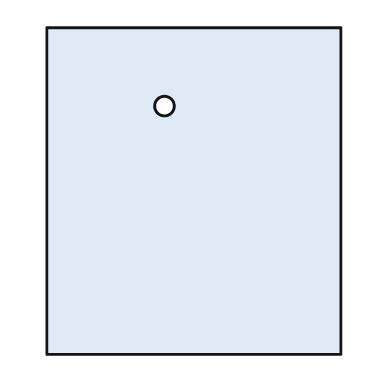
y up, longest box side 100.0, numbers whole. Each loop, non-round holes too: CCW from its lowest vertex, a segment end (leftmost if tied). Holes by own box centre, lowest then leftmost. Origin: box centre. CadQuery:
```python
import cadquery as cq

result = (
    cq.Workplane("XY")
    .moveTo(-45.0, -50.0)
    .lineTo(45.0, -50.0)
    .lineTo(45.0, 50.0)
    .lineTo(-45.0, 50.0)
    .close()
    .moveTo(-9.0, 26.0)
    .circle(3.0)
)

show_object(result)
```